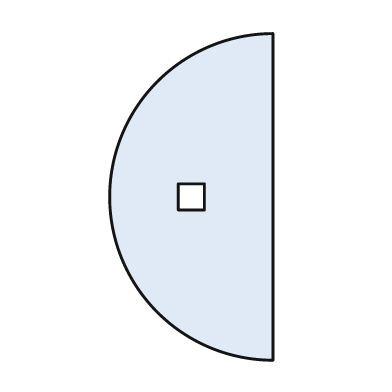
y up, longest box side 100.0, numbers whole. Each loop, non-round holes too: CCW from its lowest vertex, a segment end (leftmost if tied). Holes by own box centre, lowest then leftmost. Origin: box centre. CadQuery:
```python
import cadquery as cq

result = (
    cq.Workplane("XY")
    .moveTo(25.0, -50.0)
    .lineTo(25.0, 50.0)
    .threePointArc((-25.0, 0.0), (25.0, -50.0))
    .close()
    .moveTo(-4.0, -4.0)
    .lineTo(4.0, -4.0)
    .lineTo(4.0, 4.0)
    .lineTo(-4.0, 4.0)
    .close()
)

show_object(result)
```